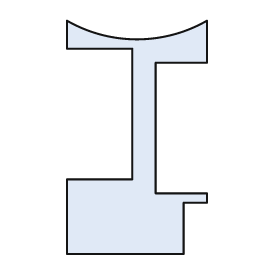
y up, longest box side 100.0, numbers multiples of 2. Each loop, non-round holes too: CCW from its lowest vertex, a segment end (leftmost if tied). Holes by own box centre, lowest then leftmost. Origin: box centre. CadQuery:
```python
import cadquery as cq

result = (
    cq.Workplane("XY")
    .moveTo(-30.0, -50.0)
    .lineTo(20.0, -50.0)
    .lineTo(20.0, -28.0)
    .lineTo(30.0, -28.0)
    .lineTo(30.0, -24.0)
    .lineTo(8.0, -24.0)
    .lineTo(8.0, 32.0)
    .lineTo(30.0, 32.0)
    .lineTo(30.0, 50.0)
    .threePointArc((0.0, 42.0), (-30.0, 50.0))
    .lineTo(-30.0, 38.0)
    .lineTo(-2.0, 38.0)
    .lineTo(-2.0, -18.0)
    .lineTo(-30.0, -18.0)
    .close()
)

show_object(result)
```